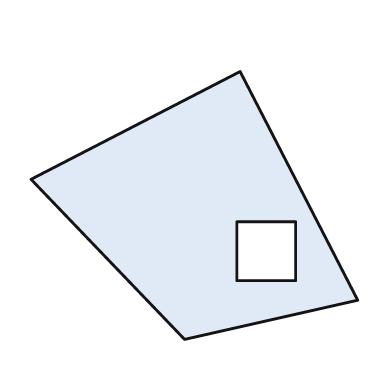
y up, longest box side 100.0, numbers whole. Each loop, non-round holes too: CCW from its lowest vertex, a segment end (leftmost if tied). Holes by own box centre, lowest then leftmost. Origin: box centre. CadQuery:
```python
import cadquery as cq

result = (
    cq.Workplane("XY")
    .moveTo(-3.0, -41.0)
    .lineTo(50.0, -29.0)
    .lineTo(14.0, 41.0)
    .lineTo(-50.0, 8.0)
    .close()
    .moveTo(13.0, -23.0)
    .lineTo(31.0, -23.0)
    .lineTo(31.0, -5.0)
    .lineTo(13.0, -5.0)
    .close()
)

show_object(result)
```